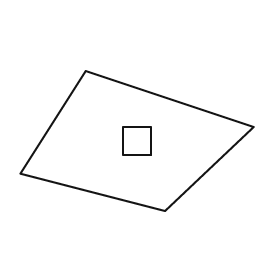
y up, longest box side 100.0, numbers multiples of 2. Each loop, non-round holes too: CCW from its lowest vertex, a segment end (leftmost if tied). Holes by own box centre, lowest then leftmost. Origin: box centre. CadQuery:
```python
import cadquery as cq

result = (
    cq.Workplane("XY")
    .moveTo(12.0, -30.0)
    .lineTo(50.0, 6.0)
    .lineTo(-22.0, 30.0)
    .lineTo(-50.0, -14.0)
    .close()
    .moveTo(-6.0, -6.0)
    .lineTo(6.0, -6.0)
    .lineTo(6.0, 6.0)
    .lineTo(-6.0, 6.0)
    .close()
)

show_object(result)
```